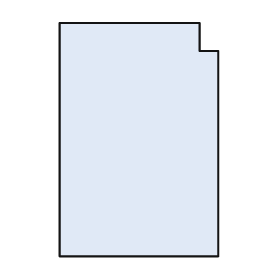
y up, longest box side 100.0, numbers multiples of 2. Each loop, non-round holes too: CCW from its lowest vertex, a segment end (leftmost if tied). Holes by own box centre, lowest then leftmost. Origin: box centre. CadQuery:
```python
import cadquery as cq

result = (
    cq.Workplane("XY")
    .moveTo(-34.0, -50.0)
    .lineTo(34.0, -50.0)
    .lineTo(34.0, 38.0)
    .lineTo(26.0, 38.0)
    .lineTo(26.0, 50.0)
    .lineTo(-34.0, 50.0)
    .close()
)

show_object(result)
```